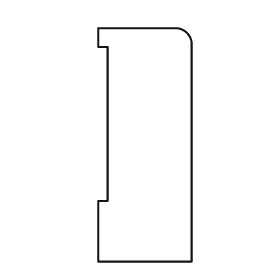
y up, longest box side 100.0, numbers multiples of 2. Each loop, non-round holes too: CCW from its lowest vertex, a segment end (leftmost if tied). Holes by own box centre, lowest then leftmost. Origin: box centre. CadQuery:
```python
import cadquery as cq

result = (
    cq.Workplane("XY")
    .moveTo(-20.0, -50.0)
    .lineTo(20.0, -50.0)
    .lineTo(20.0, 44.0)
    .threePointArc((18.0, 48.0), (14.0, 50.0))
    .lineTo(-20.0, 50.0)
    .lineTo(-20.0, 42.0)
    .lineTo(-16.0, 42.0)
    .lineTo(-16.0, -24.0)
    .lineTo(-20.0, -24.0)
    .close()
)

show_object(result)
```